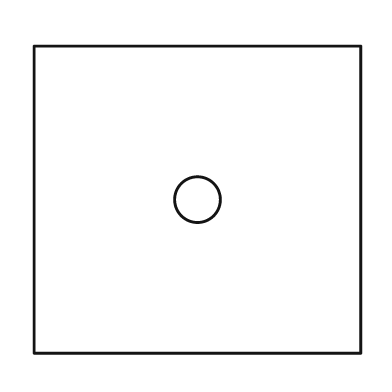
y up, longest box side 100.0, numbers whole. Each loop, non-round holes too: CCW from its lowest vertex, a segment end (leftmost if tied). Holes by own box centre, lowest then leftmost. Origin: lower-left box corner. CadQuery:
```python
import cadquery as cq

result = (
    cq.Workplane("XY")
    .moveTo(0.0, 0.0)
    .lineTo(100.0, 0.0)
    .lineTo(100.0, 94.0)
    .lineTo(0.0, 94.0)
    .close()
    .moveTo(50.0, 47.0)
    .circle(7.0)
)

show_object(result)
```